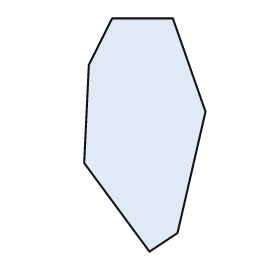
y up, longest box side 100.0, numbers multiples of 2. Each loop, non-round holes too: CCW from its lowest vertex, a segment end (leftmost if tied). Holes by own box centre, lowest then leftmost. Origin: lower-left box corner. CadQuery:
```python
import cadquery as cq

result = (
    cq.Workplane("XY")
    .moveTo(28.0, 0.0)
    .lineTo(40.0, 8.0)
    .lineTo(52.0, 60.0)
    .lineTo(38.0, 100.0)
    .lineTo(12.0, 100.0)
    .lineTo(2.0, 80.0)
    .lineTo(0.0, 38.0)
    .close()
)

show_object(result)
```